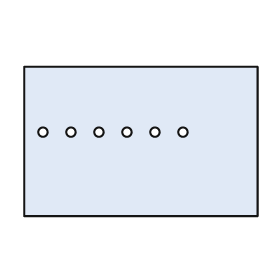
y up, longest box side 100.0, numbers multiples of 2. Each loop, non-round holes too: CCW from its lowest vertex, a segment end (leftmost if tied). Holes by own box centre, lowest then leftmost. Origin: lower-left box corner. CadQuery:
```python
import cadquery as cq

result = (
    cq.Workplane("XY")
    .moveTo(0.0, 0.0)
    .lineTo(100.0, 0.0)
    .lineTo(100.0, 64.0)
    .lineTo(0.0, 64.0)
    .close()
    .moveTo(8.0, 36.0)
    .circle(2.0)
    .moveTo(20.0, 36.0)
    .circle(2.0)
    .moveTo(32.0, 36.0)
    .circle(2.0)
    .moveTo(44.0, 36.0)
    .circle(2.0)
    .moveTo(56.0, 36.0)
    .circle(2.0)
    .moveTo(68.0, 36.0)
    .circle(2.0)
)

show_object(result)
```